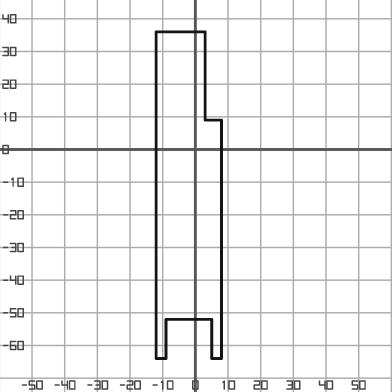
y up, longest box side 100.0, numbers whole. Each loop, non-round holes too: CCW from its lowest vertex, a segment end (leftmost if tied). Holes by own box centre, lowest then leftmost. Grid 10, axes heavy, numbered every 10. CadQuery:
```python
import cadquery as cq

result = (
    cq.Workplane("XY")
    .moveTo(-12.0, -64.0)
    .lineTo(-9.0, -64.0)
    .lineTo(-9.0, -52.0)
    .lineTo(5.0, -52.0)
    .lineTo(5.0, -64.0)
    .lineTo(8.0, -64.0)
    .lineTo(8.0, 9.0)
    .lineTo(3.0, 9.0)
    .lineTo(3.0, 36.0)
    .lineTo(-12.0, 36.0)
    .close()
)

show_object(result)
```